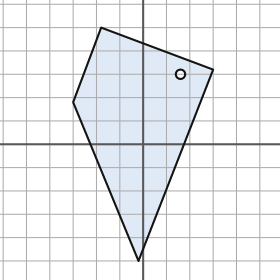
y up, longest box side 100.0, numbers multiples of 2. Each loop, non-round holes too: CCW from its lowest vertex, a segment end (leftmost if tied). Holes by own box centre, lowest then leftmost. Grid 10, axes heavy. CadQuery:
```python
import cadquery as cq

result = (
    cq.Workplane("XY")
    .moveTo(-2.0, -50.0)
    .lineTo(30.0, 32.0)
    .lineTo(-18.0, 50.0)
    .lineTo(-30.0, 18.0)
    .close()
    .moveTo(16.0, 30.0)
    .circle(2.0)
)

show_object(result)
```